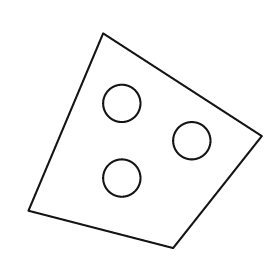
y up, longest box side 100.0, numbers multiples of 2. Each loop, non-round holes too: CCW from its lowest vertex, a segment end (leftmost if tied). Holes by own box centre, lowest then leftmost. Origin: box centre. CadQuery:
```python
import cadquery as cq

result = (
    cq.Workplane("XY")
    .moveTo(12.0, -46.0)
    .lineTo(50.0, 2.0)
    .lineTo(-18.0, 46.0)
    .lineTo(-50.0, -30.0)
    .close()
    .moveTo(-10.0, -16.0)
    .circle(8.0)
    .moveTo(20.0, 0.0)
    .circle(8.0)
    .moveTo(-10.0, 16.0)
    .circle(8.0)
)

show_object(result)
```